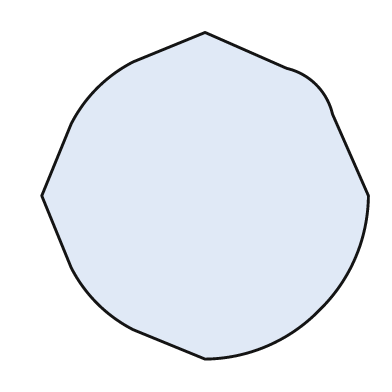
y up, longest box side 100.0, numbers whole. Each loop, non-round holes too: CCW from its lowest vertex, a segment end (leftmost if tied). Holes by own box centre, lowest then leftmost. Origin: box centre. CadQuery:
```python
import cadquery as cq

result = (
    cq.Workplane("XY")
    .moveTo(0.0, -50.0)
    .threePointArc((19.0, -46.0), (35.0, -35.0))
    .threePointArc((46.0, -19.0), (50.0, 0.0))
    .lineTo(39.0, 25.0)
    .threePointArc((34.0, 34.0), (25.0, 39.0))
    .lineTo(0.0, 50.0)
    .lineTo(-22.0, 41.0)
    .threePointArc((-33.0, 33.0), (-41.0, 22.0))
    .lineTo(-50.0, 0.0)
    .lineTo(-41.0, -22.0)
    .threePointArc((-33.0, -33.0), (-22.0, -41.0))
    .close()
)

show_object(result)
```